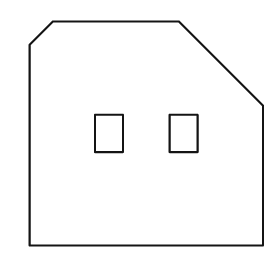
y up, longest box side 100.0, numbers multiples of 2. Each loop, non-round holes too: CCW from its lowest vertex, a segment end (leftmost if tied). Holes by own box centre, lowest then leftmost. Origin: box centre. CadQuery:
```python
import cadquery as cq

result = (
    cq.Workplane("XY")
    .moveTo(-50.0, -48.0)
    .lineTo(50.0, -48.0)
    .lineTo(50.0, 12.0)
    .lineTo(14.0, 48.0)
    .lineTo(-40.0, 48.0)
    .lineTo(-50.0, 38.0)
    .close()
    .moveTo(-22.0, -8.0)
    .lineTo(-10.0, -8.0)
    .lineTo(-10.0, 8.0)
    .lineTo(-22.0, 8.0)
    .close()
    .moveTo(10.0, -8.0)
    .lineTo(22.0, -8.0)
    .lineTo(22.0, 8.0)
    .lineTo(10.0, 8.0)
    .close()
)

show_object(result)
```